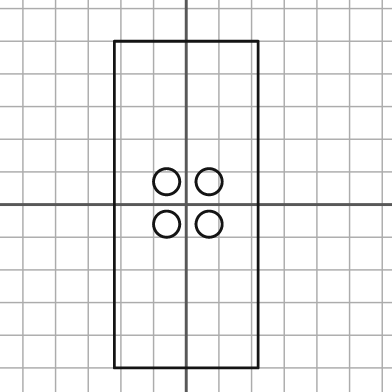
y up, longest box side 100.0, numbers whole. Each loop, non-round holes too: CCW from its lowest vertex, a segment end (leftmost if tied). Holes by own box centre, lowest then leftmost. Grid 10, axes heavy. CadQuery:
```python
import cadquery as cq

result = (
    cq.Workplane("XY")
    .moveTo(-22.0, -50.0)
    .lineTo(22.0, -50.0)
    .lineTo(22.0, 50.0)
    .lineTo(-22.0, 50.0)
    .close()
    .moveTo(-6.0, -6.0)
    .circle(4.0)
    .moveTo(7.0, -6.0)
    .circle(4.0)
    .moveTo(-6.0, 7.0)
    .circle(4.0)
    .moveTo(7.0, 7.0)
    .circle(4.0)
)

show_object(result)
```